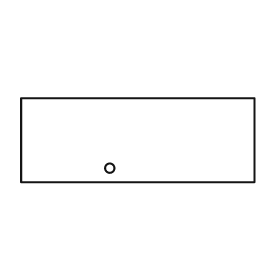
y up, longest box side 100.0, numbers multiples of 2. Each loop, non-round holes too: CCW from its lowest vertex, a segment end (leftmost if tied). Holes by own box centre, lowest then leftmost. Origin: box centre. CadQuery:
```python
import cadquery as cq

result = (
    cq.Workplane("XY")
    .moveTo(-50.0, -18.0)
    .lineTo(50.0, -18.0)
    .lineTo(50.0, 18.0)
    .lineTo(-50.0, 18.0)
    .close()
    .moveTo(-12.0, -12.0)
    .circle(2.0)
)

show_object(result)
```